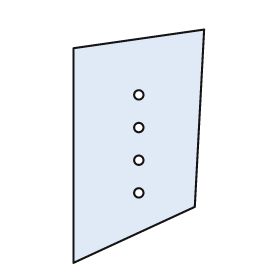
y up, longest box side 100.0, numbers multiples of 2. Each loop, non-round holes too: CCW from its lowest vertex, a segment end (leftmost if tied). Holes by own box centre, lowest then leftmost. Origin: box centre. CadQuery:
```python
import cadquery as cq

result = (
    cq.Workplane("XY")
    .moveTo(-28.0, -50.0)
    .lineTo(24.0, -26.0)
    .lineTo(28.0, 50.0)
    .lineTo(-28.0, 42.0)
    .close()
    .moveTo(0.0, -20.0)
    .circle(2.0)
    .moveTo(0.0, -6.0)
    .circle(2.0)
    .moveTo(0.0, 8.0)
    .circle(2.0)
    .moveTo(0.0, 22.0)
    .circle(2.0)
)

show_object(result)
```